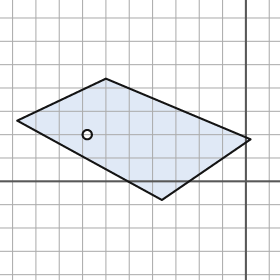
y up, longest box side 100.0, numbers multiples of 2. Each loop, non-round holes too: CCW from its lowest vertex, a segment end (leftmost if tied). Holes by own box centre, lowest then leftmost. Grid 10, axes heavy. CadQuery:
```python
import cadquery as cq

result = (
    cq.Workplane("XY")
    .moveTo(-36.0, -8.0)
    .lineTo(2.0, 18.0)
    .lineTo(-60.0, 44.0)
    .lineTo(-98.0, 26.0)
    .close()
    .moveTo(-68.0, 20.0)
    .circle(2.0)
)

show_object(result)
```